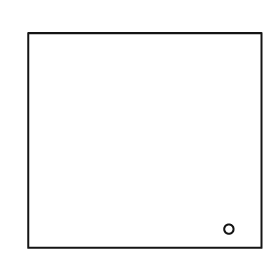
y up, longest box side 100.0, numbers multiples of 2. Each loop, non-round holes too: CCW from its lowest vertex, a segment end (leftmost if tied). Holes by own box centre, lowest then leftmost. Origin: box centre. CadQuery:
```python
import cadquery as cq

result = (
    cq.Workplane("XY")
    .moveTo(-50.0, -46.0)
    .lineTo(50.0, -46.0)
    .lineTo(50.0, 46.0)
    .lineTo(-50.0, 46.0)
    .close()
    .moveTo(36.0, -38.0)
    .circle(2.0)
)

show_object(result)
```